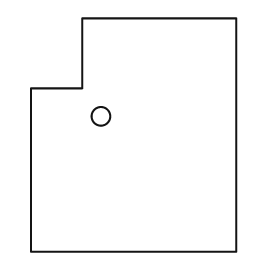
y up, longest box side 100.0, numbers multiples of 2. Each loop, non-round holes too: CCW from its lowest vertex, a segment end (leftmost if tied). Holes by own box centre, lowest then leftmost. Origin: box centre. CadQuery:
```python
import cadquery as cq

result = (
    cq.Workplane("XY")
    .moveTo(-44.0, -50.0)
    .lineTo(44.0, -50.0)
    .lineTo(44.0, 50.0)
    .lineTo(-22.0, 50.0)
    .lineTo(-22.0, 20.0)
    .lineTo(-44.0, 20.0)
    .close()
    .moveTo(-14.0, 8.0)
    .circle(4.0)
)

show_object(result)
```